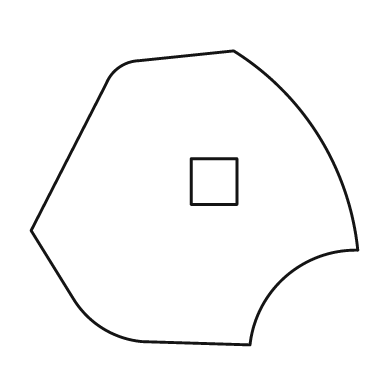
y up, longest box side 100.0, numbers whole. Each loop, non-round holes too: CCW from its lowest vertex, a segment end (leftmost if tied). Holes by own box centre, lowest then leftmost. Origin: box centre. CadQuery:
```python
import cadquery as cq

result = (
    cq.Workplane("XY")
    .moveTo(17.0, -45.0)
    .threePointArc((28.0, -24.0), (50.0, -16.0))
    .threePointArc((38.0, 19.0), (12.0, 45.0))
    .lineTo(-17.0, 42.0)
    .threePointArc((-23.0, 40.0), (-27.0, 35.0))
    .lineTo(-50.0, -10.0)
    .lineTo(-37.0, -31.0)
    .threePointArc((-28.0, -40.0), (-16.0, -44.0))
    .close()
    .moveTo(-1.0, -2.0)
    .lineTo(13.0, -2.0)
    .lineTo(13.0, 12.0)
    .lineTo(-1.0, 12.0)
    .close()
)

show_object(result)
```